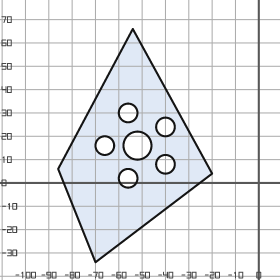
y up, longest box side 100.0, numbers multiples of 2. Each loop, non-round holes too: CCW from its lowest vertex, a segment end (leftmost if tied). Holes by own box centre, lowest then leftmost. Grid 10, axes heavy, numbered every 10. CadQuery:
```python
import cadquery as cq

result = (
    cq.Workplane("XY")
    .moveTo(-70.0, -34.0)
    .lineTo(-20.0, 4.0)
    .lineTo(-54.0, 66.0)
    .lineTo(-86.0, 6.0)
    .close()
    .moveTo(-56.0, 2.0)
    .circle(4.0)
    .moveTo(-40.0, 8.0)
    .circle(4.0)
    .moveTo(-66.0, 16.0)
    .circle(4.0)
    .moveTo(-52.0, 16.0)
    .circle(6.0)
    .moveTo(-40.0, 24.0)
    .circle(4.0)
    .moveTo(-56.0, 30.0)
    .circle(4.0)
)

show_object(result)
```